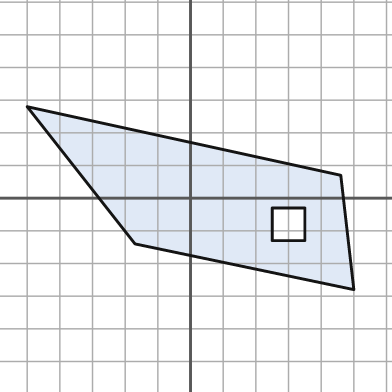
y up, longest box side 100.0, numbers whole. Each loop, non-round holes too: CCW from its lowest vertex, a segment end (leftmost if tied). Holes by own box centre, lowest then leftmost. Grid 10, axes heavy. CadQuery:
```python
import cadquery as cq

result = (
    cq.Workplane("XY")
    .moveTo(50.0, -28.0)
    .lineTo(46.0, 7.0)
    .lineTo(-50.0, 28.0)
    .lineTo(-17.0, -14.0)
    .close()
    .moveTo(25.0, -13.0)
    .lineTo(35.0, -13.0)
    .lineTo(35.0, -3.0)
    .lineTo(25.0, -3.0)
    .close()
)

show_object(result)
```